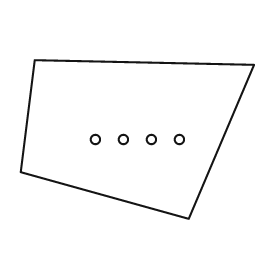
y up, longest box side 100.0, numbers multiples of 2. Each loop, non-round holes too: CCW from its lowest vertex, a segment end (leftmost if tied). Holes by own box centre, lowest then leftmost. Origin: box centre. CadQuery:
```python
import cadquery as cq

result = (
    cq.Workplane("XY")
    .moveTo(22.0, -34.0)
    .lineTo(50.0, 32.0)
    .lineTo(-44.0, 34.0)
    .lineTo(-50.0, -14.0)
    .close()
    .moveTo(-18.0, 0.0)
    .circle(2.0)
    .moveTo(-6.0, 0.0)
    .circle(2.0)
    .moveTo(6.0, 0.0)
    .circle(2.0)
    .moveTo(18.0, 0.0)
    .circle(2.0)
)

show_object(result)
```